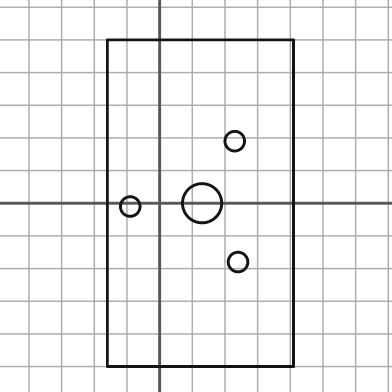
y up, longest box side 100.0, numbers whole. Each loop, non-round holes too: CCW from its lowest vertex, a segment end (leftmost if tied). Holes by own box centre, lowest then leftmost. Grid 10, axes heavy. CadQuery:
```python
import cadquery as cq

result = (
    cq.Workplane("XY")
    .moveTo(-16.0, -50.0)
    .lineTo(41.0, -50.0)
    .lineTo(41.0, 50.0)
    .lineTo(-16.0, 50.0)
    .close()
    .moveTo(24.0, -18.0)
    .circle(3.0)
    .moveTo(-9.0, -1.0)
    .circle(3.0)
    .moveTo(13.0, 0.0)
    .circle(6.0)
    .moveTo(23.0, 19.0)
    .circle(3.0)
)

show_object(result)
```